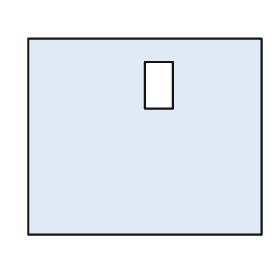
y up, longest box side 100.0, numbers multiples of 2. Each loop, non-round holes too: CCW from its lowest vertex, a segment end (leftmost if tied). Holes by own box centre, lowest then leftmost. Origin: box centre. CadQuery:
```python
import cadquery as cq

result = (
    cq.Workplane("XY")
    .moveTo(-50.0, -42.0)
    .lineTo(50.0, -42.0)
    .lineTo(50.0, 42.0)
    .lineTo(-50.0, 42.0)
    .close()
    .moveTo(0.0, 12.0)
    .lineTo(12.0, 12.0)
    .lineTo(12.0, 32.0)
    .lineTo(0.0, 32.0)
    .close()
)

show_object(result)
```